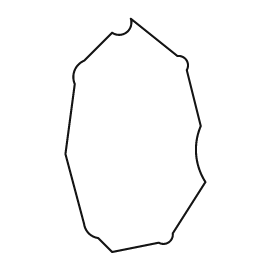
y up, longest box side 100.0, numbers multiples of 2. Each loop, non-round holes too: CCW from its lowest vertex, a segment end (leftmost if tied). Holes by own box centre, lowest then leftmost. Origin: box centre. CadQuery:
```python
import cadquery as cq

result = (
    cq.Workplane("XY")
    .moveTo(-10.0, -50.0)
    .lineTo(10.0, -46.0)
    .threePointArc((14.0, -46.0), (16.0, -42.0))
    .lineTo(30.0, -20.0)
    .threePointArc((26.0, -8.0), (28.0, 4.0))
    .lineTo(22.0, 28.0)
    .threePointArc((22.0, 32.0), (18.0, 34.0))
    .lineTo(-2.0, 50.0)
    .threePointArc((-4.0, 44.0), (-10.0, 44.0))
    .lineTo(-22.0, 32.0)
    .threePointArc((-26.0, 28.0), (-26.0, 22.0))
    .lineTo(-30.0, -8.0)
    .lineTo(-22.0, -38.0)
    .threePointArc((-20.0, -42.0), (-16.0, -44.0))
    .close()
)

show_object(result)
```